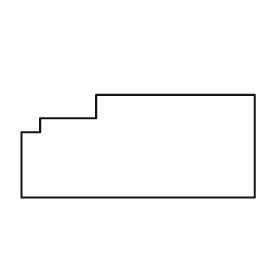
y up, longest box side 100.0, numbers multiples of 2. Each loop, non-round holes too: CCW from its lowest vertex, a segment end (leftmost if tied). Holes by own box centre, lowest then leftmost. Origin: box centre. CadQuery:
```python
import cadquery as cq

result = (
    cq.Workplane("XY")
    .moveTo(-50.0, -22.0)
    .lineTo(50.0, -22.0)
    .lineTo(50.0, 22.0)
    .lineTo(-18.0, 22.0)
    .lineTo(-18.0, 12.0)
    .lineTo(-42.0, 12.0)
    .lineTo(-42.0, 6.0)
    .lineTo(-50.0, 6.0)
    .close()
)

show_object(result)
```